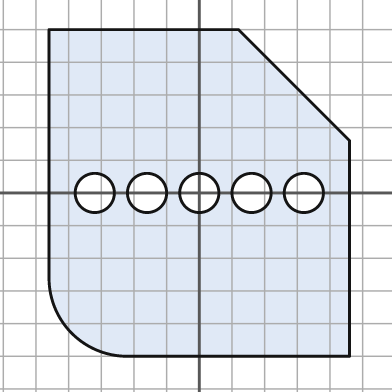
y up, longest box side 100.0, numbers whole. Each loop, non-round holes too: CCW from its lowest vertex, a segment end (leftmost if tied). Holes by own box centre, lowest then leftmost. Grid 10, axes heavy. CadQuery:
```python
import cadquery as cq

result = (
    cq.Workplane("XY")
    .moveTo(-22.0, -50.0)
    .lineTo(46.0, -50.0)
    .lineTo(46.0, 16.0)
    .lineTo(12.0, 50.0)
    .lineTo(-46.0, 50.0)
    .lineTo(-46.0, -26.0)
    .threePointArc((-39.0, -43.0), (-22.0, -50.0))
    .close()
    .moveTo(-32.0, 0.0)
    .circle(6.0)
    .moveTo(-16.0, 0.0)
    .circle(6.0)
    .moveTo(0.0, 0.0)
    .circle(6.0)
    .moveTo(16.0, 0.0)
    .circle(6.0)
    .moveTo(32.0, 0.0)
    .circle(6.0)
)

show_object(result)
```